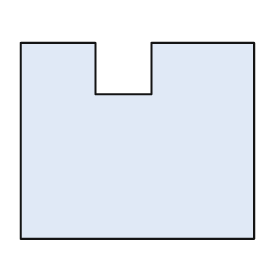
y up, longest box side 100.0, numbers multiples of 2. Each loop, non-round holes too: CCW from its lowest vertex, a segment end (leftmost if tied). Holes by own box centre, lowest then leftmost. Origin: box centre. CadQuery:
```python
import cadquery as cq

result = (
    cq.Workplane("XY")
    .moveTo(-50.0, -42.0)
    .lineTo(50.0, -42.0)
    .lineTo(50.0, 42.0)
    .lineTo(6.0, 42.0)
    .lineTo(6.0, 20.0)
    .lineTo(-18.0, 20.0)
    .lineTo(-18.0, 42.0)
    .lineTo(-50.0, 42.0)
    .close()
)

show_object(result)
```